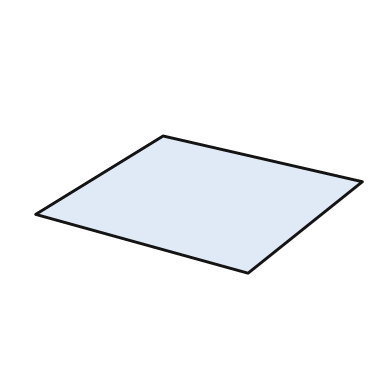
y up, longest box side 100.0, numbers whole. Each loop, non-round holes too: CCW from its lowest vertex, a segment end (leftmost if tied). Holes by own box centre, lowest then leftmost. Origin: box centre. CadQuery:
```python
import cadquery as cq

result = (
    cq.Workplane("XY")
    .moveTo(15.0, -21.0)
    .lineTo(50.0, 7.0)
    .lineTo(-11.0, 21.0)
    .lineTo(-50.0, -3.0)
    .close()
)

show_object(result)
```